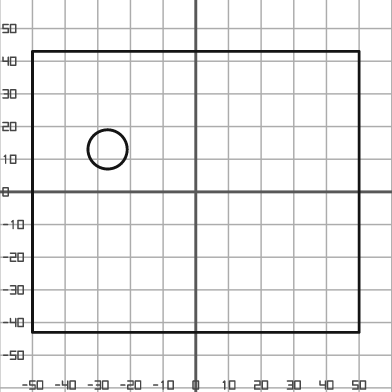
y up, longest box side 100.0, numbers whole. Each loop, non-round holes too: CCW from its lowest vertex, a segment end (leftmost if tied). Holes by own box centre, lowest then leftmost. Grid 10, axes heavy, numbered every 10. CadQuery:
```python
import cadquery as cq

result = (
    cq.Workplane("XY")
    .moveTo(-50.0, -43.0)
    .lineTo(50.0, -43.0)
    .lineTo(50.0, 43.0)
    .lineTo(-50.0, 43.0)
    .close()
    .moveTo(-27.0, 13.0)
    .circle(6.0)
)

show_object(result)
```